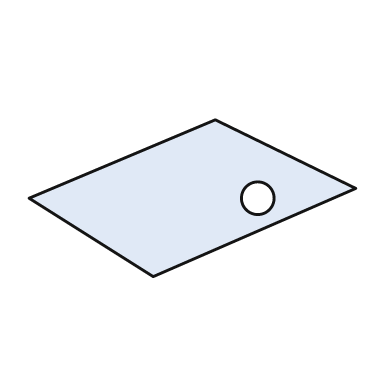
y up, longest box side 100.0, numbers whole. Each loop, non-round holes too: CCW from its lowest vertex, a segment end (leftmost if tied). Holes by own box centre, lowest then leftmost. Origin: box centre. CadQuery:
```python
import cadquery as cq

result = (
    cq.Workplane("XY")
    .moveTo(-12.0, -24.0)
    .lineTo(50.0, 3.0)
    .lineTo(7.0, 24.0)
    .lineTo(-50.0, 0.0)
    .close()
    .moveTo(20.0, 0.0)
    .circle(5.0)
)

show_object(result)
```